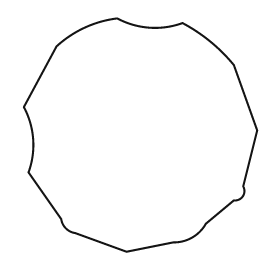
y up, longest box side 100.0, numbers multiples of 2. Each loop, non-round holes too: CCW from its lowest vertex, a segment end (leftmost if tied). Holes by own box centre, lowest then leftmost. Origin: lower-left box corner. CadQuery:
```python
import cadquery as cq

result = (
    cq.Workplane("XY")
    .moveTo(44.0, 0.0)
    .lineTo(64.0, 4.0)
    .threePointArc((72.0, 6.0), (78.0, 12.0))
    .lineTo(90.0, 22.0)
    .threePointArc((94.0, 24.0), (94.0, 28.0))
    .lineTo(100.0, 52.0)
    .lineTo(90.0, 80.0)
    .threePointArc((80.0, 90.0), (68.0, 98.0))
    .threePointArc((54.0, 96.0), (40.0, 100.0))
    .threePointArc((26.0, 96.0), (14.0, 88.0))
    .lineTo(0.0, 62.0)
    .threePointArc((4.0, 48.0), (2.0, 34.0))
    .lineTo(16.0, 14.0)
    .threePointArc((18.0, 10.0), (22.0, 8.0))
    .close()
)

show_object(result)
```